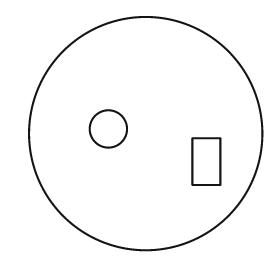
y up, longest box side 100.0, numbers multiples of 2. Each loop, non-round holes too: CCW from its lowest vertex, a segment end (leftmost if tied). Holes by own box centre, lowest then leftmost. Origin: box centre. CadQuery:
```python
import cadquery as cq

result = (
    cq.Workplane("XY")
    .moveTo(0.0, 0.0)
    .circle(50.0)
    .moveTo(20.0, -22.0)
    .lineTo(32.0, -22.0)
    .lineTo(32.0, -2.0)
    .lineTo(20.0, -2.0)
    .close()
    .moveTo(-16.0, 2.0)
    .circle(8.0)
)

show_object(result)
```